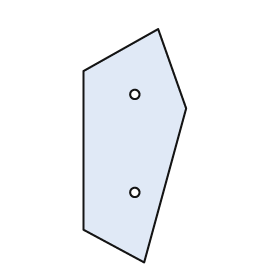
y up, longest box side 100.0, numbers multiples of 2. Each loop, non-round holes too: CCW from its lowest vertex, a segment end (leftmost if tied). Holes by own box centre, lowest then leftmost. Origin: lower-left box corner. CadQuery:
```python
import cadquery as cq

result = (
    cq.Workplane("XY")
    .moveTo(26.0, 0.0)
    .lineTo(44.0, 66.0)
    .lineTo(32.0, 100.0)
    .lineTo(0.0, 82.0)
    .lineTo(0.0, 14.0)
    .close()
    .moveTo(22.0, 30.0)
    .circle(2.0)
    .moveTo(22.0, 72.0)
    .circle(2.0)
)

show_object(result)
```